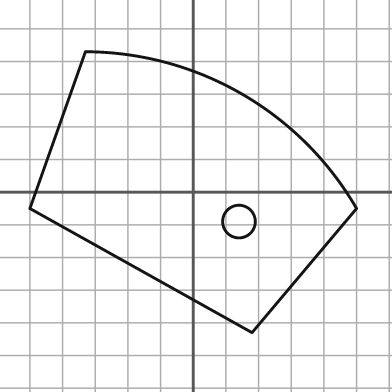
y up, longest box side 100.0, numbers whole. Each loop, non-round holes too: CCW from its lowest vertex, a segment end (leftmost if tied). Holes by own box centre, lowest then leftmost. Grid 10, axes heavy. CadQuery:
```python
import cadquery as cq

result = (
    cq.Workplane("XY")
    .moveTo(18.0, -43.0)
    .lineTo(50.0, -5.0)
    .threePointArc((15.0, 30.0), (-33.0, 43.0))
    .lineTo(-50.0, -5.0)
    .close()
    .moveTo(14.0, -9.0)
    .circle(5.0)
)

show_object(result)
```